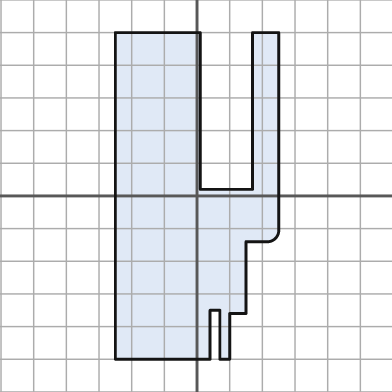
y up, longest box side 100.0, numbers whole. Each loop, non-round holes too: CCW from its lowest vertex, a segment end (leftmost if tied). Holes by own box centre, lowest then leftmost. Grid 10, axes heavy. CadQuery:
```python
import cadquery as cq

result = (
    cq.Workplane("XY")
    .moveTo(-25.0, -50.0)
    .lineTo(4.0, -50.0)
    .lineTo(4.0, -35.0)
    .lineTo(7.0, -35.0)
    .lineTo(7.0, -50.0)
    .lineTo(10.0, -50.0)
    .lineTo(10.0, -36.0)
    .lineTo(15.0, -36.0)
    .lineTo(15.0, -14.0)
    .lineTo(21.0, -14.0)
    .threePointArc((24.0, -13.0), (25.0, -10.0))
    .lineTo(25.0, 50.0)
    .lineTo(17.0, 50.0)
    .lineTo(17.0, 2.0)
    .lineTo(1.0, 2.0)
    .lineTo(1.0, 50.0)
    .lineTo(-25.0, 50.0)
    .close()
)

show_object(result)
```